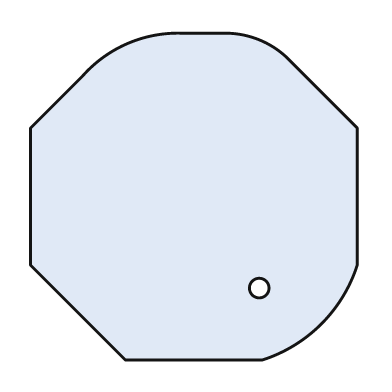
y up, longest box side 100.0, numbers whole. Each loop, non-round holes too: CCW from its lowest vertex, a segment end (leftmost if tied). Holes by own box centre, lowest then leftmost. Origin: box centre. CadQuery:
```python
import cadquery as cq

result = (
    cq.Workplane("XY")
    .moveTo(-21.0, -50.0)
    .lineTo(21.0, -50.0)
    .threePointArc((39.0, -39.0), (50.0, -21.0))
    .lineTo(50.0, 21.0)
    .lineTo(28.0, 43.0)
    .threePointArc((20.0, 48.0), (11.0, 50.0))
    .lineTo(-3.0, 50.0)
    .threePointArc((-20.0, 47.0), (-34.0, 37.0))
    .lineTo(-50.0, 21.0)
    .lineTo(-50.0, -21.0)
    .close()
    .moveTo(20.0, -28.0)
    .circle(3.0)
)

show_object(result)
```